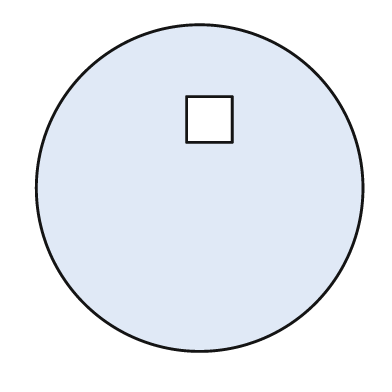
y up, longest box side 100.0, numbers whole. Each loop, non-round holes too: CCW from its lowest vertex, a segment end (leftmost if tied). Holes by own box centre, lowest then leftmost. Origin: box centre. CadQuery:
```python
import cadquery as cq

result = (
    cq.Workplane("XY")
    .moveTo(0.0, 0.0)
    .circle(50.0)
    .moveTo(-4.0, 14.0)
    .lineTo(10.0, 14.0)
    .lineTo(10.0, 28.0)
    .lineTo(-4.0, 28.0)
    .close()
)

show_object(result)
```